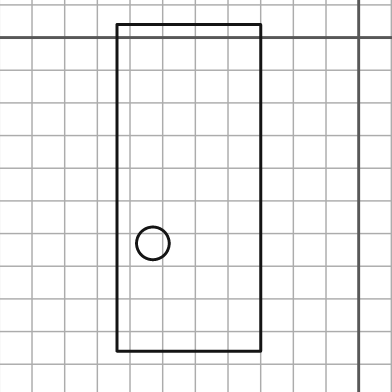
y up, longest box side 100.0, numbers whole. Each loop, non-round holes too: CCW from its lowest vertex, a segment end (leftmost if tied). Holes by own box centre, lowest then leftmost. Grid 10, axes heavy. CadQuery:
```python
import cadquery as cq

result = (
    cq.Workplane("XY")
    .moveTo(-74.0, -96.0)
    .lineTo(-30.0, -96.0)
    .lineTo(-30.0, 4.0)
    .lineTo(-74.0, 4.0)
    .close()
    .moveTo(-63.0, -63.0)
    .circle(5.0)
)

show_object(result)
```